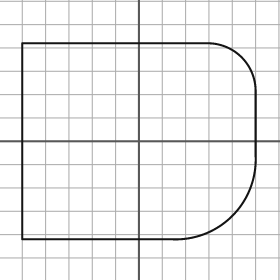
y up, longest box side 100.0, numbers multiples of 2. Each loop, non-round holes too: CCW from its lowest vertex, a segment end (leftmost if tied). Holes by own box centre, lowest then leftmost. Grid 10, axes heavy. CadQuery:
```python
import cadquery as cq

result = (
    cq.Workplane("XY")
    .moveTo(-50.0, -42.0)
    .lineTo(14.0, -42.0)
    .threePointArc((40.0, -32.0), (50.0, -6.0))
    .lineTo(50.0, 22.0)
    .threePointArc((44.0, 36.0), (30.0, 42.0))
    .lineTo(-50.0, 42.0)
    .close()
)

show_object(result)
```